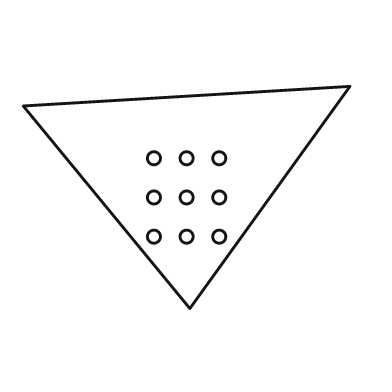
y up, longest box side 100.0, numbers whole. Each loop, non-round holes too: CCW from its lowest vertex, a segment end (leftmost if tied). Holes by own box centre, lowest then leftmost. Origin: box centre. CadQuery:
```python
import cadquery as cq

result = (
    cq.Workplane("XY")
    .moveTo(1.0, -34.0)
    .lineTo(50.0, 34.0)
    .lineTo(-50.0, 28.0)
    .close()
    .moveTo(-10.0, -12.0)
    .circle(2.0)
    .moveTo(0.0, -12.0)
    .circle(2.0)
    .moveTo(10.0, -12.0)
    .circle(2.0)
    .moveTo(-10.0, 0.0)
    .circle(2.0)
    .moveTo(0.0, 0.0)
    .circle(2.0)
    .moveTo(10.0, 0.0)
    .circle(2.0)
    .moveTo(-10.0, 12.0)
    .circle(2.0)
    .moveTo(0.0, 12.0)
    .circle(2.0)
    .moveTo(10.0, 12.0)
    .circle(2.0)
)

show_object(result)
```